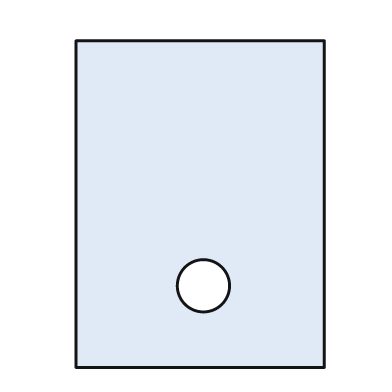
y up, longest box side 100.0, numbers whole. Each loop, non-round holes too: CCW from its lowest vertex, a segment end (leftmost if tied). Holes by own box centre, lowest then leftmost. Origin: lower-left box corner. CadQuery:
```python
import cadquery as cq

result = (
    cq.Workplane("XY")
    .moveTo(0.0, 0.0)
    .lineTo(76.0, 0.0)
    .lineTo(76.0, 100.0)
    .lineTo(0.0, 100.0)
    .close()
    .moveTo(39.0, 25.0)
    .circle(8.0)
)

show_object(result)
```